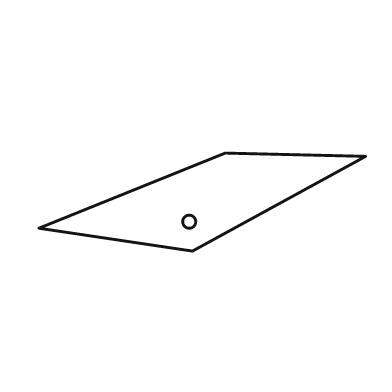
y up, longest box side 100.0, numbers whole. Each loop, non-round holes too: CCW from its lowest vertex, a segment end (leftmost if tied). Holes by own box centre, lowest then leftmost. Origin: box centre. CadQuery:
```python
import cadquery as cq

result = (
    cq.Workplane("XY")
    .moveTo(-3.0, -15.0)
    .lineTo(50.0, 14.0)
    .lineTo(7.0, 15.0)
    .lineTo(-50.0, -8.0)
    .close()
    .moveTo(-4.0, -6.0)
    .circle(2.0)
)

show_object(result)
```